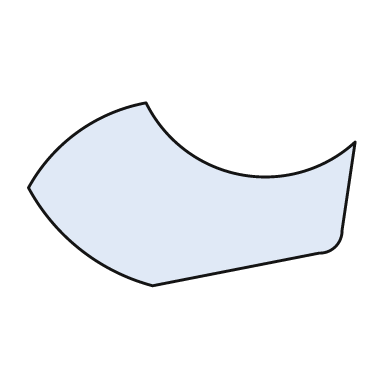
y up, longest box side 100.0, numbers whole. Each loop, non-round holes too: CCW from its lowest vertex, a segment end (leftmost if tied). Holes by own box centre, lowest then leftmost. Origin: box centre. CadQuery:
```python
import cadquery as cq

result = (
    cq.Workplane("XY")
    .moveTo(-12.0, -28.0)
    .lineTo(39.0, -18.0)
    .threePointArc((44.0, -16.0), (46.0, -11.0))
    .lineTo(50.0, 16.0)
    .threePointArc((15.0, 6.0), (-14.0, 28.0))
    .threePointArc((-35.0, 19.0), (-50.0, 2.0))
    .threePointArc((-34.0, -17.0), (-12.0, -28.0))
    .close()
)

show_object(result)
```